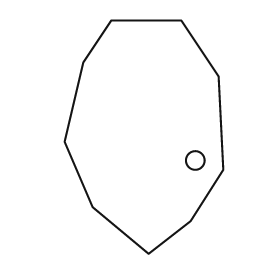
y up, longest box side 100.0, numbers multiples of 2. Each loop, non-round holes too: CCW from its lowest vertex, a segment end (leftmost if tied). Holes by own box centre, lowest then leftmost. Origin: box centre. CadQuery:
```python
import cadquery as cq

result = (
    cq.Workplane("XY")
    .moveTo(2.0, -50.0)
    .lineTo(20.0, -36.0)
    .lineTo(34.0, -14.0)
    .lineTo(32.0, 26.0)
    .lineTo(16.0, 50.0)
    .lineTo(-14.0, 50.0)
    .lineTo(-26.0, 32.0)
    .lineTo(-34.0, -2.0)
    .lineTo(-22.0, -30.0)
    .close()
    .moveTo(22.0, -10.0)
    .circle(4.0)
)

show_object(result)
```